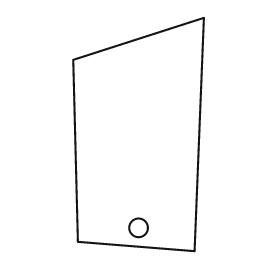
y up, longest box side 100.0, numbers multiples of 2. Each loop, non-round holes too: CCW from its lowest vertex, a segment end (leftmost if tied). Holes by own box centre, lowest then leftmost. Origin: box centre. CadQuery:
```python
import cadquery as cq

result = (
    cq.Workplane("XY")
    .moveTo(24.0, -50.0)
    .lineTo(28.0, 50.0)
    .lineTo(-28.0, 32.0)
    .lineTo(-26.0, -46.0)
    .close()
    .moveTo(0.0, -40.0)
    .circle(4.0)
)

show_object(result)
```